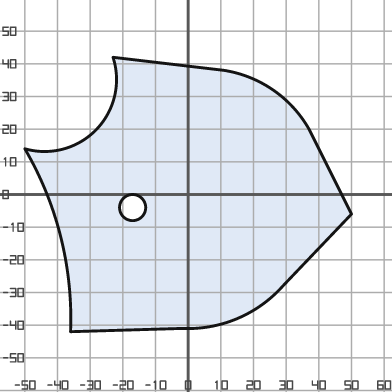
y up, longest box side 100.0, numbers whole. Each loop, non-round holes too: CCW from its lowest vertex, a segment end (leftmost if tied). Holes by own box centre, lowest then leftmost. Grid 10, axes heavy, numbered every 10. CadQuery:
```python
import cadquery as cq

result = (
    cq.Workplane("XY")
    .moveTo(-36.0, -42.0)
    .lineTo(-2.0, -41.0)
    .threePointArc((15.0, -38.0), (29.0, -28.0))
    .lineTo(50.0, -6.0)
    .lineTo(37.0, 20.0)
    .threePointArc((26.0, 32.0), (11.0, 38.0))
    .lineTo(-23.0, 42.0)
    .threePointArc((-28.0, 20.0), (-50.0, 14.0))
    .threePointArc((-39.0, -13.0), (-36.0, -42.0))
    .close()
    .moveTo(-17.0, -4.0)
    .circle(4.0)
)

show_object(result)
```